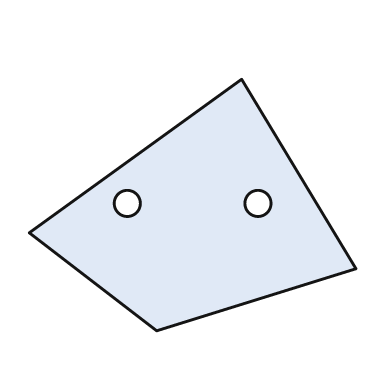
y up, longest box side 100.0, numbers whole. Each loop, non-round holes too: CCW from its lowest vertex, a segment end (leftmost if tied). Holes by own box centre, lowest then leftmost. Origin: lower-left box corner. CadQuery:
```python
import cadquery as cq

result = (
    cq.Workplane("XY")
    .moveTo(39.0, 0.0)
    .lineTo(100.0, 19.0)
    .lineTo(65.0, 77.0)
    .lineTo(0.0, 30.0)
    .close()
    .moveTo(30.0, 39.0)
    .circle(4.0)
    .moveTo(70.0, 39.0)
    .circle(4.0)
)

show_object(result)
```